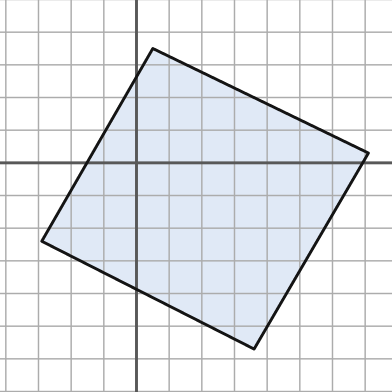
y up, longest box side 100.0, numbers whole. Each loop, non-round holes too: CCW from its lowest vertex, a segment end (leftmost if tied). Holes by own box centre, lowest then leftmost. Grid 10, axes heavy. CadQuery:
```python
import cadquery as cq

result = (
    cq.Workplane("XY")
    .moveTo(36.0, -57.0)
    .lineTo(71.0, 3.0)
    .lineTo(5.0, 35.0)
    .lineTo(-29.0, -24.0)
    .close()
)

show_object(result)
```